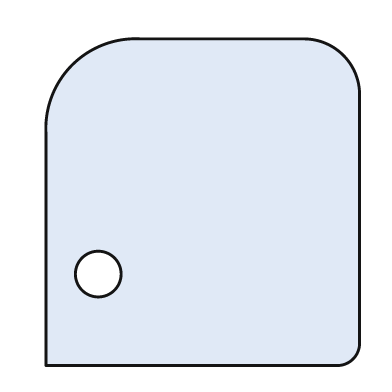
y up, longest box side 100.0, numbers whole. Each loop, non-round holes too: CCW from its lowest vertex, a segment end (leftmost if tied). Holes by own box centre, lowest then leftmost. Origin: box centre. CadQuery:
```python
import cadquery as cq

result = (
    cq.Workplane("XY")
    .moveTo(-48.0, -50.0)
    .lineTo(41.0, -50.0)
    .threePointArc((46.0, -48.0), (48.0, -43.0))
    .lineTo(48.0, 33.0)
    .threePointArc((43.0, 45.0), (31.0, 50.0))
    .lineTo(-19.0, 50.0)
    .threePointArc((-40.0, 42.0), (-48.0, 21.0))
    .close()
    .moveTo(-32.0, -22.0)
    .circle(7.0)
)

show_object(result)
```